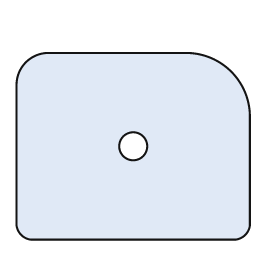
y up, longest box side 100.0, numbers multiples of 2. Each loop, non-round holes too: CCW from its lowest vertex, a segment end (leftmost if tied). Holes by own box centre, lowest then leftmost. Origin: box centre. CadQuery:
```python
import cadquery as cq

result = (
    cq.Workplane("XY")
    .moveTo(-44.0, -40.0)
    .lineTo(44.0, -40.0)
    .threePointArc((48.0, -38.0), (50.0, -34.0))
    .lineTo(50.0, 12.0)
    .threePointArc((42.0, 32.0), (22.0, 40.0))
    .lineTo(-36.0, 40.0)
    .threePointArc((-46.0, 36.0), (-50.0, 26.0))
    .lineTo(-50.0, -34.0)
    .threePointArc((-48.0, -38.0), (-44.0, -40.0))
    .close()
    .moveTo(0.0, 0.0)
    .circle(6.0)
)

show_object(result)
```